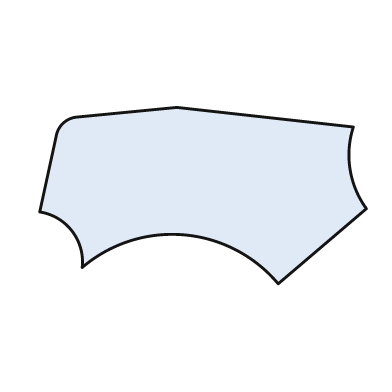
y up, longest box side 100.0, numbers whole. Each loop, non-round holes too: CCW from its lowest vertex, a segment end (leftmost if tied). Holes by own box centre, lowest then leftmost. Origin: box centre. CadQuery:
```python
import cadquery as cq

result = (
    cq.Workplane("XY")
    .moveTo(23.0, -27.0)
    .lineTo(50.0, -4.0)
    .threePointArc((45.0, 8.0), (46.0, 21.0))
    .lineTo(-8.0, 27.0)
    .lineTo(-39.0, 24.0)
    .threePointArc((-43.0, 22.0), (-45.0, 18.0))
    .lineTo(-50.0, -5.0)
    .threePointArc((-40.0, -11.0), (-37.0, -22.0))
    .threePointArc((-6.0, -12.0), (23.0, -27.0))
    .close()
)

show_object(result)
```